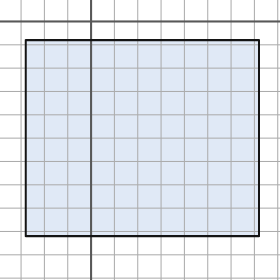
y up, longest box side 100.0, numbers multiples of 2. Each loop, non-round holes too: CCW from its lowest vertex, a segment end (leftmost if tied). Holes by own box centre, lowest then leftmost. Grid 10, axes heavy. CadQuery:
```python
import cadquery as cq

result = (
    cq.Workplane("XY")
    .moveTo(-28.0, -92.0)
    .lineTo(72.0, -92.0)
    .lineTo(72.0, -8.0)
    .lineTo(-28.0, -8.0)
    .close()
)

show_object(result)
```